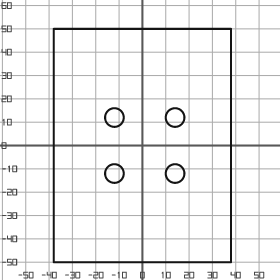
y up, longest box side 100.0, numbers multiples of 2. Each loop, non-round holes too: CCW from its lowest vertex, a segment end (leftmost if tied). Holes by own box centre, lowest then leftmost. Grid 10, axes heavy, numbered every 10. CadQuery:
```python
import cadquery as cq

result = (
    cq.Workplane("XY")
    .moveTo(-38.0, -50.0)
    .lineTo(38.0, -50.0)
    .lineTo(38.0, 50.0)
    .lineTo(-38.0, 50.0)
    .close()
    .moveTo(-12.0, -12.0)
    .circle(4.0)
    .moveTo(14.0, -12.0)
    .circle(4.0)
    .moveTo(-12.0, 12.0)
    .circle(4.0)
    .moveTo(14.0, 12.0)
    .circle(4.0)
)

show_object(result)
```